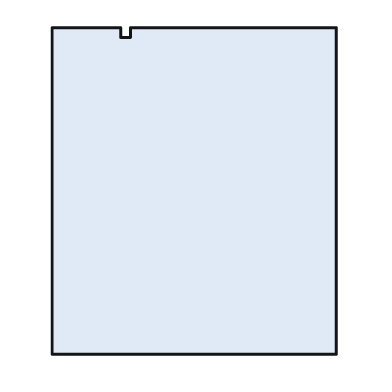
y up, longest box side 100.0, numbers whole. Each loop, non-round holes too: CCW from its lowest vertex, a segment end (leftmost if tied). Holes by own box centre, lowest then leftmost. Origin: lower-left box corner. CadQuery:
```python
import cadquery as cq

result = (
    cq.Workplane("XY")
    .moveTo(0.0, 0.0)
    .lineTo(87.0, 0.0)
    .lineTo(87.0, 100.0)
    .lineTo(24.0, 100.0)
    .lineTo(24.0, 97.0)
    .lineTo(21.0, 97.0)
    .lineTo(21.0, 100.0)
    .lineTo(0.0, 100.0)
    .close()
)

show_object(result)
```